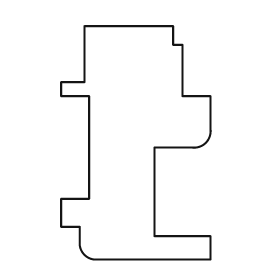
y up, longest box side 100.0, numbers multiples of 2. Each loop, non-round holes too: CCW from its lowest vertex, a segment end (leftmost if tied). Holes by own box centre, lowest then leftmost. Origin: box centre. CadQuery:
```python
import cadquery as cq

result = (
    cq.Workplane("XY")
    .moveTo(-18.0, -50.0)
    .lineTo(32.0, -50.0)
    .lineTo(32.0, -40.0)
    .lineTo(8.0, -40.0)
    .lineTo(8.0, -2.0)
    .lineTo(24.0, -2.0)
    .threePointArc((30.0, 0.0), (32.0, 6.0))
    .lineTo(32.0, 20.0)
    .lineTo(20.0, 20.0)
    .lineTo(20.0, 42.0)
    .lineTo(16.0, 42.0)
    .lineTo(16.0, 50.0)
    .lineTo(-22.0, 50.0)
    .lineTo(-22.0, 26.0)
    .lineTo(-32.0, 26.0)
    .lineTo(-32.0, 20.0)
    .lineTo(-20.0, 20.0)
    .lineTo(-20.0, -24.0)
    .lineTo(-32.0, -24.0)
    .lineTo(-32.0, -36.0)
    .lineTo(-24.0, -36.0)
    .lineTo(-24.0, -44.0)
    .threePointArc((-22.0, -48.0), (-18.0, -50.0))
    .close()
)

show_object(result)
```